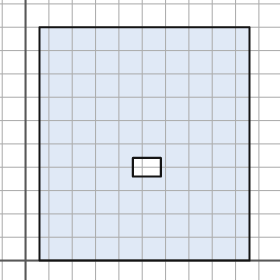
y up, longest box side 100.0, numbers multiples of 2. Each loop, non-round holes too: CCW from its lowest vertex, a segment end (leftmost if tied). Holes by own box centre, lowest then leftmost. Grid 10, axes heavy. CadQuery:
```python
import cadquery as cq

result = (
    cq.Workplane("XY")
    .moveTo(6.0, 0.0)
    .lineTo(96.0, 0.0)
    .lineTo(96.0, 100.0)
    .lineTo(6.0, 100.0)
    .close()
    .moveTo(46.0, 36.0)
    .lineTo(58.0, 36.0)
    .lineTo(58.0, 44.0)
    .lineTo(46.0, 44.0)
    .close()
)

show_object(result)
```